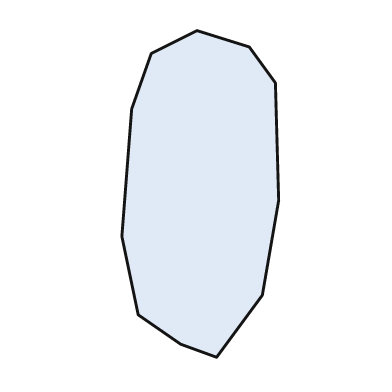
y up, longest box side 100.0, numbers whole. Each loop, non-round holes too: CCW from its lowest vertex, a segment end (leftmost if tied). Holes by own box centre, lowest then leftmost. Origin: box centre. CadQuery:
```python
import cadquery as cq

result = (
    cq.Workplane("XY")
    .moveTo(5.0, -50.0)
    .lineTo(19.0, -31.0)
    .lineTo(24.0, -2.0)
    .lineTo(23.0, 34.0)
    .lineTo(15.0, 45.0)
    .lineTo(-1.0, 50.0)
    .lineTo(-15.0, 43.0)
    .lineTo(-21.0, 26.0)
    .lineTo(-24.0, -13.0)
    .lineTo(-19.0, -37.0)
    .lineTo(-6.0, -46.0)
    .close()
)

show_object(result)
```